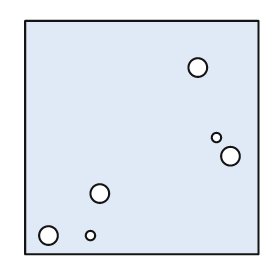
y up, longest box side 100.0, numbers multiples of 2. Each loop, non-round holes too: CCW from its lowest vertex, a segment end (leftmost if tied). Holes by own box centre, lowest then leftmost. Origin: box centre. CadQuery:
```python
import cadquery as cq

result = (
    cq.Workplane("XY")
    .moveTo(-50.0, -50.0)
    .lineTo(50.0, -50.0)
    .lineTo(50.0, 50.0)
    .lineTo(-50.0, 50.0)
    .close()
    .moveTo(-40.0, -42.0)
    .circle(4.0)
    .moveTo(-22.0, -42.0)
    .circle(2.0)
    .moveTo(-18.0, -24.0)
    .circle(4.0)
    .moveTo(38.0, -8.0)
    .circle(4.0)
    .moveTo(32.0, 0.0)
    .circle(2.0)
    .moveTo(24.0, 30.0)
    .circle(4.0)
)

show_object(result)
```